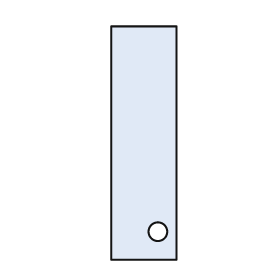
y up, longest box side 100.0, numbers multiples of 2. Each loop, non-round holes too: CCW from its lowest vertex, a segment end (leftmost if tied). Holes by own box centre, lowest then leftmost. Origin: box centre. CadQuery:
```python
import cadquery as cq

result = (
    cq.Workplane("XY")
    .moveTo(-14.0, -50.0)
    .lineTo(14.0, -50.0)
    .lineTo(14.0, 50.0)
    .lineTo(-14.0, 50.0)
    .close()
    .moveTo(6.0, -38.0)
    .circle(4.0)
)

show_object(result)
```